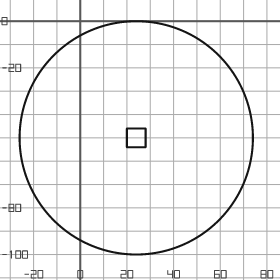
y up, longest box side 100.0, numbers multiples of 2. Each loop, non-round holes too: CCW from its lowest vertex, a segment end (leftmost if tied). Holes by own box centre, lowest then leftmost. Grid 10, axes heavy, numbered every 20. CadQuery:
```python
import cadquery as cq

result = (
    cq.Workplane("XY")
    .moveTo(24.0, -50.0)
    .circle(50.0)
    .moveTo(20.0, -54.0)
    .lineTo(28.0, -54.0)
    .lineTo(28.0, -46.0)
    .lineTo(20.0, -46.0)
    .close()
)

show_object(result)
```